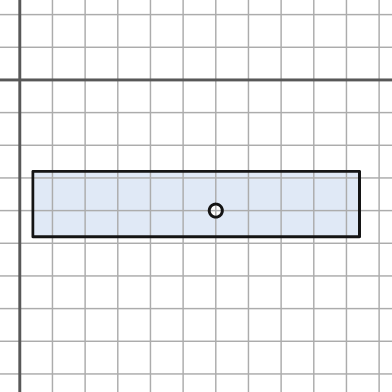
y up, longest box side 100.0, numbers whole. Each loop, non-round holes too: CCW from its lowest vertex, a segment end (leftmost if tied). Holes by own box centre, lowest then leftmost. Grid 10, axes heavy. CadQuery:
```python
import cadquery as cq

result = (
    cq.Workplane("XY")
    .moveTo(4.0, -48.0)
    .lineTo(104.0, -48.0)
    .lineTo(104.0, -28.0)
    .lineTo(4.0, -28.0)
    .close()
    .moveTo(60.0, -40.0)
    .circle(2.0)
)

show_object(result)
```